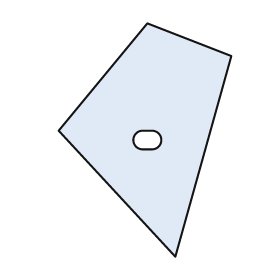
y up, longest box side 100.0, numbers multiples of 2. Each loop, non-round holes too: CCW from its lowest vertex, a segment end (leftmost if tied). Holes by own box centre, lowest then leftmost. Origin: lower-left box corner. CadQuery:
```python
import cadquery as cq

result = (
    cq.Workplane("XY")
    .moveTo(50.0, 0.0)
    .lineTo(74.0, 86.0)
    .lineTo(38.0, 100.0)
    .lineTo(0.0, 54.0)
    .close()
    .moveTo(36.0, 46.0)
    .lineTo(40.0, 46.0)
    .threePointArc((44.0, 50.0), (40.0, 54.0))
    .lineTo(36.0, 54.0)
    .threePointArc((32.0, 50.0), (36.0, 46.0))
    .close()
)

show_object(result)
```